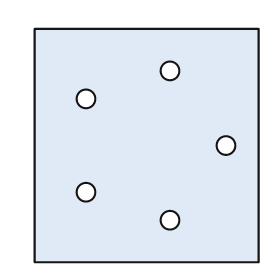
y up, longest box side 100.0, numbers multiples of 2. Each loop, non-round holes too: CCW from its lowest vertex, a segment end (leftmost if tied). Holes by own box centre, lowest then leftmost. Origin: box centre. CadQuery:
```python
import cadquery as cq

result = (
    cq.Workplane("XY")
    .moveTo(-48.0, -50.0)
    .lineTo(48.0, -50.0)
    .lineTo(48.0, 50.0)
    .lineTo(-48.0, 50.0)
    .close()
    .moveTo(10.0, -32.0)
    .circle(4.0)
    .moveTo(-26.0, -20.0)
    .circle(4.0)
    .moveTo(34.0, 0.0)
    .circle(4.0)
    .moveTo(-26.0, 20.0)
    .circle(4.0)
    .moveTo(10.0, 32.0)
    .circle(4.0)
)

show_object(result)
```